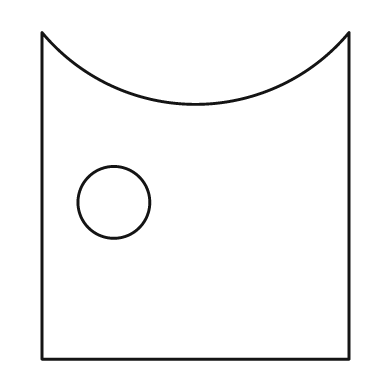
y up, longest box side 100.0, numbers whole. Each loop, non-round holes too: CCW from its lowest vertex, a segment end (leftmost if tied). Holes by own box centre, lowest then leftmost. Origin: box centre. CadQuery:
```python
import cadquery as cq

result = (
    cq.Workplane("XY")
    .moveTo(-47.0, -50.0)
    .lineTo(47.0, -50.0)
    .lineTo(47.0, 50.0)
    .threePointArc((0.0, 28.0), (-47.0, 50.0))
    .close()
    .moveTo(-25.0, -2.0)
    .circle(11.0)
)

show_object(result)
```